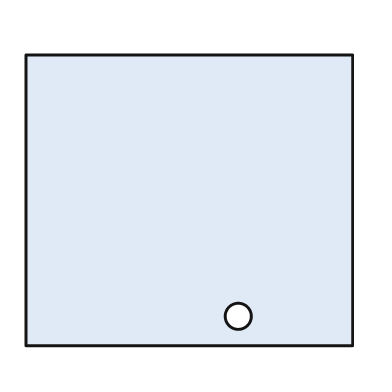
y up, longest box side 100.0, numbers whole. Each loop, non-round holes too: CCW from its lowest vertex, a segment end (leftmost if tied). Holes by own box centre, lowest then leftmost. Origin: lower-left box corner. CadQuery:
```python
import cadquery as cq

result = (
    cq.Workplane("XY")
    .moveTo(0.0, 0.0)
    .lineTo(100.0, 0.0)
    .lineTo(100.0, 89.0)
    .lineTo(0.0, 89.0)
    .close()
    .moveTo(65.0, 9.0)
    .circle(4.0)
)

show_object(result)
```